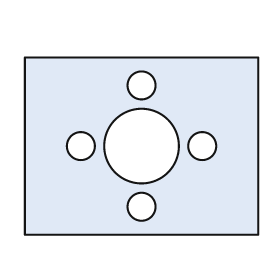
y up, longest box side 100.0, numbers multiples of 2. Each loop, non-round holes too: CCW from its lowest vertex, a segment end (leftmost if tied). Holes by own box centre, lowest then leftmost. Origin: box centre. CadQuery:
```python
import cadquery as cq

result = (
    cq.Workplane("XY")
    .moveTo(-50.0, -38.0)
    .lineTo(50.0, -38.0)
    .lineTo(50.0, 38.0)
    .lineTo(-50.0, 38.0)
    .close()
    .moveTo(0.0, -26.0)
    .circle(6.0)
    .moveTo(-26.0, 0.0)
    .circle(6.0)
    .moveTo(0.0, 0.0)
    .circle(16.0)
    .moveTo(26.0, 0.0)
    .circle(6.0)
    .moveTo(0.0, 26.0)
    .circle(6.0)
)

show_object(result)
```